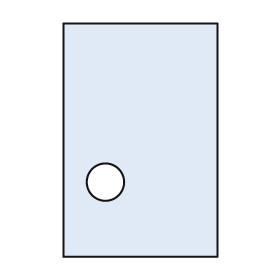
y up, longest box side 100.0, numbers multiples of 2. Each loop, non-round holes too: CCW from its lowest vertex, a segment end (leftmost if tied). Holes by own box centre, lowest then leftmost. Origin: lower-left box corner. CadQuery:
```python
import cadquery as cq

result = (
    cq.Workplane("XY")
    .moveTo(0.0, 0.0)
    .lineTo(66.0, 0.0)
    .lineTo(66.0, 100.0)
    .lineTo(0.0, 100.0)
    .close()
    .moveTo(18.0, 32.0)
    .circle(8.0)
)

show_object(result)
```